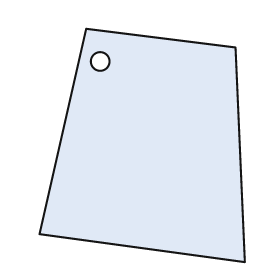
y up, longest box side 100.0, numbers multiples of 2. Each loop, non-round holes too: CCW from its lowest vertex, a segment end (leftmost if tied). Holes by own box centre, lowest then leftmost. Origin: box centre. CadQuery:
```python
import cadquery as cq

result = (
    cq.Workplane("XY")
    .moveTo(44.0, -50.0)
    .lineTo(40.0, 42.0)
    .lineTo(-24.0, 50.0)
    .lineTo(-44.0, -38.0)
    .close()
    .moveTo(-18.0, 36.0)
    .circle(4.0)
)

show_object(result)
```